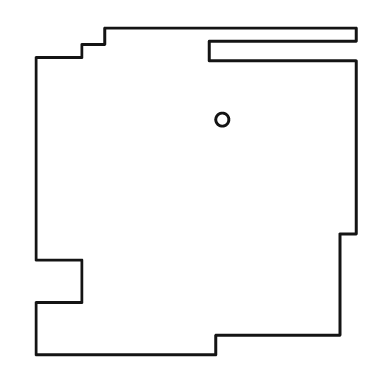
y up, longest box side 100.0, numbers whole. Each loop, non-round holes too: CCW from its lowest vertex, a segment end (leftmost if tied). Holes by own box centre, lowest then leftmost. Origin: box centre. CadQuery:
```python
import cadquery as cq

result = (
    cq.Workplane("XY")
    .moveTo(-49.0, -50.0)
    .lineTo(6.0, -50.0)
    .lineTo(6.0, -44.0)
    .lineTo(44.0, -44.0)
    .lineTo(44.0, -13.0)
    .lineTo(49.0, -13.0)
    .lineTo(49.0, 40.0)
    .lineTo(4.0, 40.0)
    .lineTo(4.0, 46.0)
    .lineTo(49.0, 46.0)
    .lineTo(49.0, 50.0)
    .lineTo(-28.0, 50.0)
    .lineTo(-28.0, 45.0)
    .lineTo(-35.0, 45.0)
    .lineTo(-35.0, 41.0)
    .lineTo(-49.0, 41.0)
    .lineTo(-49.0, -21.0)
    .lineTo(-35.0, -21.0)
    .lineTo(-35.0, -34.0)
    .lineTo(-49.0, -34.0)
    .close()
    .moveTo(8.0, 22.0)
    .circle(2.0)
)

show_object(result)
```